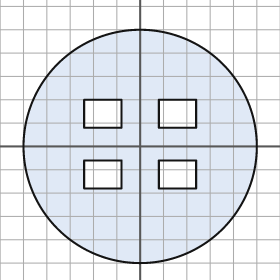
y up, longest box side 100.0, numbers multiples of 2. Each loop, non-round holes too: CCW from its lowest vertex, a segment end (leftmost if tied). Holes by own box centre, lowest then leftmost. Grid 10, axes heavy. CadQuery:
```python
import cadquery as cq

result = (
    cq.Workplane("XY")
    .moveTo(0.0, 0.0)
    .circle(50.0)
    .moveTo(-24.0, -18.0)
    .lineTo(-8.0, -18.0)
    .lineTo(-8.0, -6.0)
    .lineTo(-24.0, -6.0)
    .close()
    .moveTo(8.0, -18.0)
    .lineTo(24.0, -18.0)
    .lineTo(24.0, -6.0)
    .lineTo(8.0, -6.0)
    .close()
    .moveTo(-24.0, 8.0)
    .lineTo(-8.0, 8.0)
    .lineTo(-8.0, 20.0)
    .lineTo(-24.0, 20.0)
    .close()
    .moveTo(8.0, 8.0)
    .lineTo(24.0, 8.0)
    .lineTo(24.0, 20.0)
    .lineTo(8.0, 20.0)
    .close()
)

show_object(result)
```